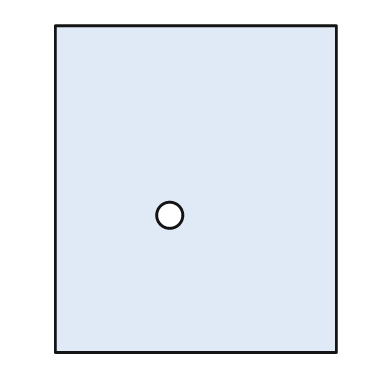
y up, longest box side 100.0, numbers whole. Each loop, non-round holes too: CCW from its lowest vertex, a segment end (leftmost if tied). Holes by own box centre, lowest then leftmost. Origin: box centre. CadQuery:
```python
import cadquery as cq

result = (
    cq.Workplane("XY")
    .moveTo(-43.0, -50.0)
    .lineTo(43.0, -50.0)
    .lineTo(43.0, 50.0)
    .lineTo(-43.0, 50.0)
    .close()
    .moveTo(-8.0, -8.0)
    .circle(4.0)
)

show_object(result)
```